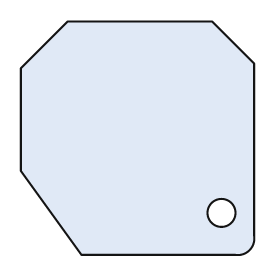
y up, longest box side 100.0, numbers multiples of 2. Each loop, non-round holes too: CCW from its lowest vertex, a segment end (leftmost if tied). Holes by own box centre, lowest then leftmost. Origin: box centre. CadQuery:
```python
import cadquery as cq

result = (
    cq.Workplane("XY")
    .moveTo(-24.0, -50.0)
    .lineTo(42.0, -50.0)
    .threePointArc((48.0, -48.0), (50.0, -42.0))
    .lineTo(50.0, 32.0)
    .lineTo(32.0, 50.0)
    .lineTo(-30.0, 50.0)
    .lineTo(-50.0, 30.0)
    .lineTo(-50.0, -14.0)
    .close()
    .moveTo(36.0, -32.0)
    .circle(6.0)
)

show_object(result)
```